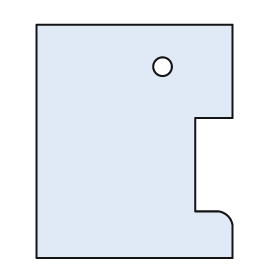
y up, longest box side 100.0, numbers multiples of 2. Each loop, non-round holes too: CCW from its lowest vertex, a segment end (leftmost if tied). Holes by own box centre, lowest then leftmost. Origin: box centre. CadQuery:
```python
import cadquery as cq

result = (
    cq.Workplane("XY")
    .moveTo(-42.0, -50.0)
    .lineTo(42.0, -50.0)
    .lineTo(42.0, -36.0)
    .threePointArc((40.0, -32.0), (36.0, -30.0))
    .lineTo(26.0, -30.0)
    .lineTo(26.0, 10.0)
    .lineTo(42.0, 10.0)
    .lineTo(42.0, 50.0)
    .lineTo(-42.0, 50.0)
    .close()
    .moveTo(12.0, 32.0)
    .circle(4.0)
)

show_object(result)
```